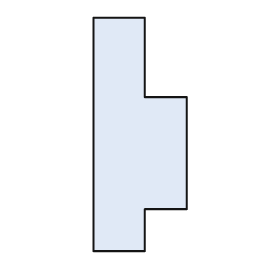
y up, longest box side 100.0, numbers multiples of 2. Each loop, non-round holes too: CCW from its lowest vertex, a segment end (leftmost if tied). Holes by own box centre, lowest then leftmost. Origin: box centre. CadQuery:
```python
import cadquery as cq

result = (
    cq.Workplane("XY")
    .moveTo(-20.0, -50.0)
    .lineTo(2.0, -50.0)
    .lineTo(2.0, -32.0)
    .lineTo(20.0, -32.0)
    .lineTo(20.0, 16.0)
    .lineTo(2.0, 16.0)
    .lineTo(2.0, 50.0)
    .lineTo(-20.0, 50.0)
    .close()
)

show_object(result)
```